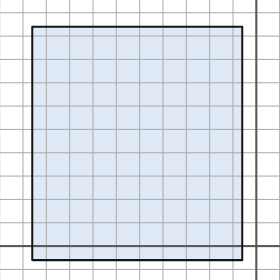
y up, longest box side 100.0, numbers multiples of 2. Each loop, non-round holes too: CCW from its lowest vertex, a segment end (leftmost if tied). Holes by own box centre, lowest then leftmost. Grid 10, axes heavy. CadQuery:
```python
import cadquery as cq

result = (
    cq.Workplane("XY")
    .moveTo(-96.0, -6.0)
    .lineTo(-6.0, -6.0)
    .lineTo(-6.0, 94.0)
    .lineTo(-96.0, 94.0)
    .close()
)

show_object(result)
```